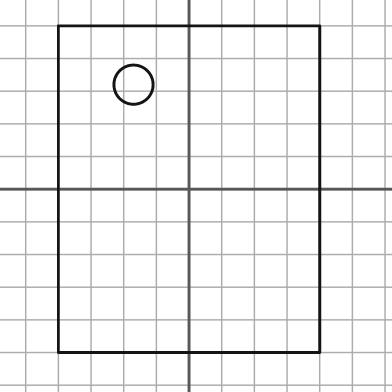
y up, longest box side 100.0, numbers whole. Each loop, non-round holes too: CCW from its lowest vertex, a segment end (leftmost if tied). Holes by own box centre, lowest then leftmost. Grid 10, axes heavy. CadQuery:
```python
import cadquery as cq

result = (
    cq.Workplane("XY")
    .moveTo(-40.0, -50.0)
    .lineTo(40.0, -50.0)
    .lineTo(40.0, 50.0)
    .lineTo(-40.0, 50.0)
    .close()
    .moveTo(-17.0, 32.0)
    .circle(6.0)
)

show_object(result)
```